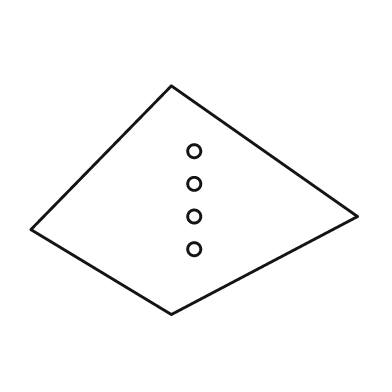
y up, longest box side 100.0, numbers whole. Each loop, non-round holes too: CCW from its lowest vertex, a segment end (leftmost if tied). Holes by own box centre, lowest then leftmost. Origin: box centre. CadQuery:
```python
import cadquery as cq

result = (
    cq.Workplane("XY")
    .moveTo(-7.0, -35.0)
    .lineTo(50.0, -5.0)
    .lineTo(-7.0, 35.0)
    .lineTo(-50.0, -9.0)
    .close()
    .moveTo(0.0, -15.0)
    .circle(2.0)
    .moveTo(0.0, -5.0)
    .circle(2.0)
    .moveTo(0.0, 5.0)
    .circle(2.0)
    .moveTo(0.0, 15.0)
    .circle(2.0)
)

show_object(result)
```